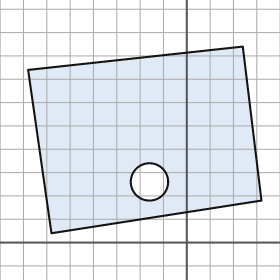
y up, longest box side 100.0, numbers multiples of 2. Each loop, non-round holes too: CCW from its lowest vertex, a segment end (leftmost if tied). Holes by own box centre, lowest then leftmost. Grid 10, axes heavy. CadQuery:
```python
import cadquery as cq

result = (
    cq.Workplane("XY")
    .moveTo(-58.0, 4.0)
    .lineTo(32.0, 18.0)
    .lineTo(24.0, 84.0)
    .lineTo(-68.0, 74.0)
    .close()
    .moveTo(-16.0, 26.0)
    .circle(8.0)
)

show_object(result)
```